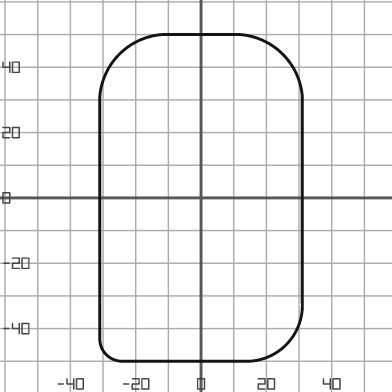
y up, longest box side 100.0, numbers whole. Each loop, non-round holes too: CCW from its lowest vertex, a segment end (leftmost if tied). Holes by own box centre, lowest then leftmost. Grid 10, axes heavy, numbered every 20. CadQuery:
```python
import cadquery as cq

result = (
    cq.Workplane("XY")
    .moveTo(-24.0, -50.0)
    .lineTo(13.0, -50.0)
    .threePointArc((26.0, -45.0), (31.0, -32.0))
    .lineTo(31.0, 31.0)
    .threePointArc((25.0, 44.0), (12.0, 50.0))
    .lineTo(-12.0, 50.0)
    .threePointArc((-25.0, 44.0), (-31.0, 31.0))
    .lineTo(-31.0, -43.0)
    .threePointArc((-29.0, -48.0), (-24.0, -50.0))
    .close()
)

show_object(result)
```